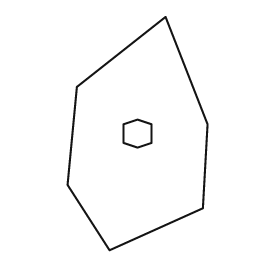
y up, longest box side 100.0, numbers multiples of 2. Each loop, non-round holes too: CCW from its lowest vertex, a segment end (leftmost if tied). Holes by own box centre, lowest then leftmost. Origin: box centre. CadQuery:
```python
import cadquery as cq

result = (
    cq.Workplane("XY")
    .moveTo(-12.0, -50.0)
    .lineTo(28.0, -32.0)
    .lineTo(30.0, 4.0)
    .lineTo(12.0, 50.0)
    .lineTo(-26.0, 20.0)
    .lineTo(-30.0, -22.0)
    .close()
    .moveTo(0.0, -6.0)
    .lineTo(6.0, -4.0)
    .lineTo(6.0, 4.0)
    .lineTo(0.0, 6.0)
    .lineTo(-6.0, 4.0)
    .lineTo(-6.0, -4.0)
    .close()
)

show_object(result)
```